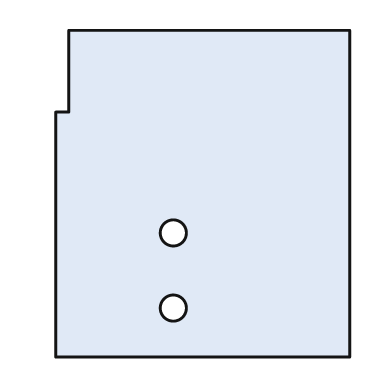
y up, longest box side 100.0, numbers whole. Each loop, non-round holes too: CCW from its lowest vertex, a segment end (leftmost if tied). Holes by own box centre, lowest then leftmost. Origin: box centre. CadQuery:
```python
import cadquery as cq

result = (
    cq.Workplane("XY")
    .moveTo(-45.0, -50.0)
    .lineTo(45.0, -50.0)
    .lineTo(45.0, 50.0)
    .lineTo(-41.0, 50.0)
    .lineTo(-41.0, 25.0)
    .lineTo(-45.0, 25.0)
    .close()
    .moveTo(-9.0, -35.0)
    .circle(4.0)
    .moveTo(-9.0, -12.0)
    .circle(4.0)
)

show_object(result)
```